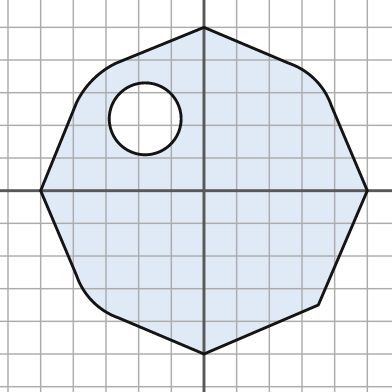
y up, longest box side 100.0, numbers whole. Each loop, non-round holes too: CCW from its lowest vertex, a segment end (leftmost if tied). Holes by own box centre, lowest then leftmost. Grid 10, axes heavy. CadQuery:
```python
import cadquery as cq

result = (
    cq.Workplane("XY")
    .moveTo(0.0, -50.0)
    .lineTo(35.0, -35.0)
    .lineTo(50.0, 0.0)
    .lineTo(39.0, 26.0)
    .threePointArc((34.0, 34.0), (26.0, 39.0))
    .lineTo(0.0, 50.0)
    .lineTo(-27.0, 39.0)
    .threePointArc((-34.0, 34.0), (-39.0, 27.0))
    .lineTo(-50.0, 0.0)
    .lineTo(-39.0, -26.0)
    .threePointArc((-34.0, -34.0), (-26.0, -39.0))
    .close()
    .moveTo(-18.0, 22.0)
    .circle(11.0)
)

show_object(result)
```